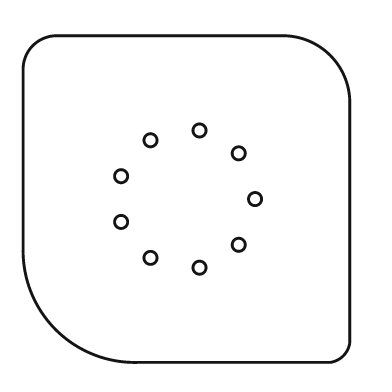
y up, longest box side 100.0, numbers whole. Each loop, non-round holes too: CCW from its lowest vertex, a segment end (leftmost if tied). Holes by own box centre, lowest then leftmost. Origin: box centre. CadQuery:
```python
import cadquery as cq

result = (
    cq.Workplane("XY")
    .moveTo(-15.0, -50.0)
    .lineTo(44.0, -50.0)
    .threePointArc((48.0, -48.0), (50.0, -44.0))
    .lineTo(50.0, 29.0)
    .threePointArc((44.0, 44.0), (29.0, 50.0))
    .lineTo(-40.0, 50.0)
    .threePointArc((-47.0, 47.0), (-50.0, 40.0))
    .lineTo(-50.0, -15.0)
    .threePointArc((-40.0, -40.0), (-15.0, -50.0))
    .close()
    .moveTo(4.0, -21.0)
    .circle(2.0)
    .moveTo(-11.0, -18.0)
    .circle(2.0)
    .moveTo(16.0, -14.0)
    .circle(2.0)
    .moveTo(-20.0, -7.0)
    .circle(2.0)
    .moveTo(21.0, 0.0)
    .circle(2.0)
    .moveTo(-20.0, 7.0)
    .circle(2.0)
    .moveTo(16.0, 14.0)
    .circle(2.0)
    .moveTo(-11.0, 18.0)
    .circle(2.0)
    .moveTo(4.0, 21.0)
    .circle(2.0)
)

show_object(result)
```